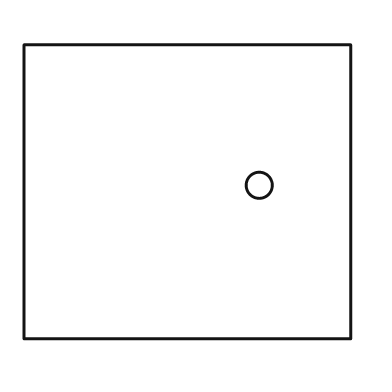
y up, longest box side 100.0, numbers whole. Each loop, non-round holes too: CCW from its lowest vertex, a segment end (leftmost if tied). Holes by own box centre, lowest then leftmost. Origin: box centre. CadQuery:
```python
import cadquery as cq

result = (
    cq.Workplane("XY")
    .moveTo(-50.0, -45.0)
    .lineTo(50.0, -45.0)
    .lineTo(50.0, 45.0)
    .lineTo(-50.0, 45.0)
    .close()
    .moveTo(22.0, 2.0)
    .circle(4.0)
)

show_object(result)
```